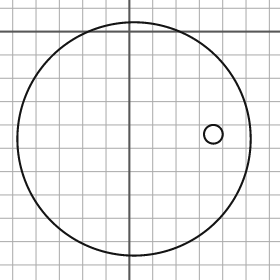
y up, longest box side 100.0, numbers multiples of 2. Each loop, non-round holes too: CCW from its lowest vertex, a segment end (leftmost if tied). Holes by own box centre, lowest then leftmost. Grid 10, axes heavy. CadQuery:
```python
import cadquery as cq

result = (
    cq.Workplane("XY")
    .moveTo(2.0, -46.0)
    .circle(50.0)
    .moveTo(36.0, -44.0)
    .circle(4.0)
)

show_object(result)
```